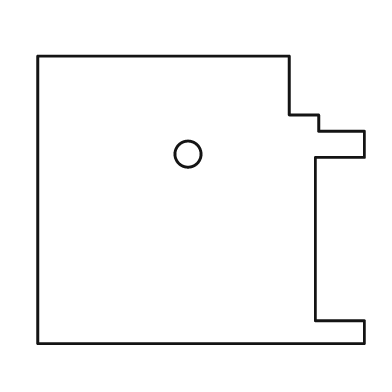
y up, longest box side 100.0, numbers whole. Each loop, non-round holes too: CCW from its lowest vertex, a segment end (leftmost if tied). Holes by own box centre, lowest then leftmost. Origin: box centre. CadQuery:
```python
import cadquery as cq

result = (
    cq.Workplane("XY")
    .moveTo(-50.0, -44.0)
    .lineTo(50.0, -44.0)
    .lineTo(50.0, -37.0)
    .lineTo(35.0, -37.0)
    .lineTo(35.0, 13.0)
    .lineTo(50.0, 13.0)
    .lineTo(50.0, 21.0)
    .lineTo(36.0, 21.0)
    .lineTo(36.0, 26.0)
    .lineTo(27.0, 26.0)
    .lineTo(27.0, 44.0)
    .lineTo(-50.0, 44.0)
    .close()
    .moveTo(-4.0, 14.0)
    .circle(4.0)
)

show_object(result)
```